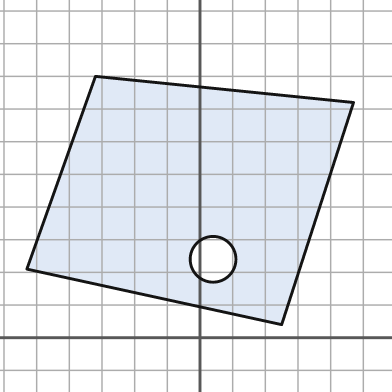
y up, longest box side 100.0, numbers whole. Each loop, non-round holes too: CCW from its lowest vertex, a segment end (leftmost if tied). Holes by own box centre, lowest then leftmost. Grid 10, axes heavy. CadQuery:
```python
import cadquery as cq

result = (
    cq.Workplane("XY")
    .moveTo(25.0, 4.0)
    .lineTo(47.0, 72.0)
    .lineTo(-32.0, 80.0)
    .lineTo(-53.0, 21.0)
    .close()
    .moveTo(4.0, 24.0)
    .circle(7.0)
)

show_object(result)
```